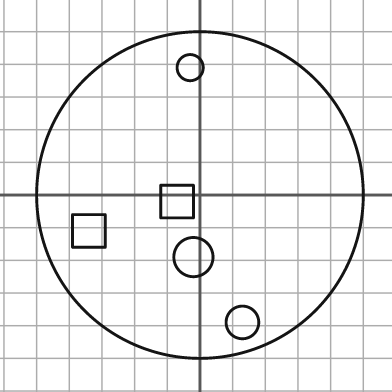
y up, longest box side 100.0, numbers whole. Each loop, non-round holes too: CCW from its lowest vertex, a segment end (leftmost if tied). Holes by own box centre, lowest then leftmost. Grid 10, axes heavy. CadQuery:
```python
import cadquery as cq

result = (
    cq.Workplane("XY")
    .moveTo(0.0, 0.0)
    .circle(50.0)
    .moveTo(13.0, -39.0)
    .circle(5.0)
    .moveTo(-2.0, -19.0)
    .circle(6.0)
    .moveTo(-39.0, -16.0)
    .lineTo(-29.0, -16.0)
    .lineTo(-29.0, -6.0)
    .lineTo(-39.0, -6.0)
    .close()
    .moveTo(-12.0, -7.0)
    .lineTo(-2.0, -7.0)
    .lineTo(-2.0, 3.0)
    .lineTo(-12.0, 3.0)
    .close()
    .moveTo(-3.0, 39.0)
    .circle(4.0)
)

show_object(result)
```